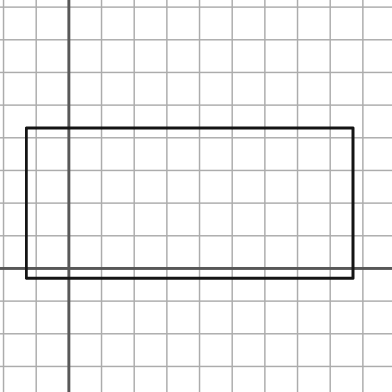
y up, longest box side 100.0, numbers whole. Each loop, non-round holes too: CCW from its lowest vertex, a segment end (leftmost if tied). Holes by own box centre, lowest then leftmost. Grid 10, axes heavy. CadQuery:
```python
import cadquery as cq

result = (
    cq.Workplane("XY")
    .moveTo(-13.0, -3.0)
    .lineTo(87.0, -3.0)
    .lineTo(87.0, 43.0)
    .lineTo(-13.0, 43.0)
    .close()
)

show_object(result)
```